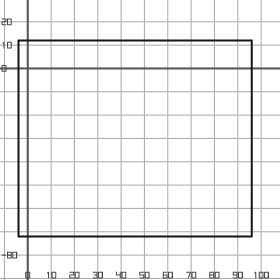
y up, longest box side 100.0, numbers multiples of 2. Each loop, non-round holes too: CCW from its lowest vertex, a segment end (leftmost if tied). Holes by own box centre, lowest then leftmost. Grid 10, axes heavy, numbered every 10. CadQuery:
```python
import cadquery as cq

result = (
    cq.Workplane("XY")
    .moveTo(-4.0, -72.0)
    .lineTo(96.0, -72.0)
    .lineTo(96.0, 12.0)
    .lineTo(-4.0, 12.0)
    .close()
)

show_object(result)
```